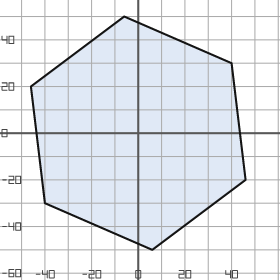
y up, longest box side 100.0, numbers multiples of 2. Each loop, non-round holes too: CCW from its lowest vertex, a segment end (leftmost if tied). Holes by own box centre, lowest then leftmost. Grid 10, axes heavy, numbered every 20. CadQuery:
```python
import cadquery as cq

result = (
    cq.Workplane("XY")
    .moveTo(6.0, -50.0)
    .lineTo(46.0, -20.0)
    .lineTo(40.0, 30.0)
    .lineTo(-6.0, 50.0)
    .lineTo(-46.0, 20.0)
    .lineTo(-40.0, -30.0)
    .close()
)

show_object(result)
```